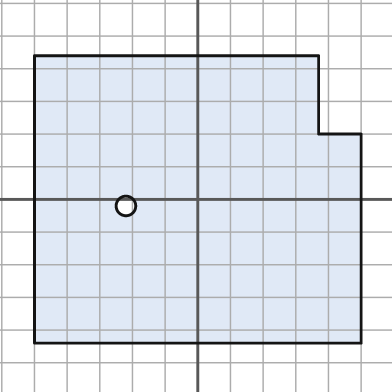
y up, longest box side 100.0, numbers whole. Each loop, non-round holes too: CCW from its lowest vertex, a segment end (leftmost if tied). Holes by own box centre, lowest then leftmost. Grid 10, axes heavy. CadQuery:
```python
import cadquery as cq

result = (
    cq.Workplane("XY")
    .moveTo(-50.0, -44.0)
    .lineTo(50.0, -44.0)
    .lineTo(50.0, 20.0)
    .lineTo(37.0, 20.0)
    .lineTo(37.0, 44.0)
    .lineTo(-50.0, 44.0)
    .close()
    .moveTo(-22.0, -2.0)
    .circle(3.0)
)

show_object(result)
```